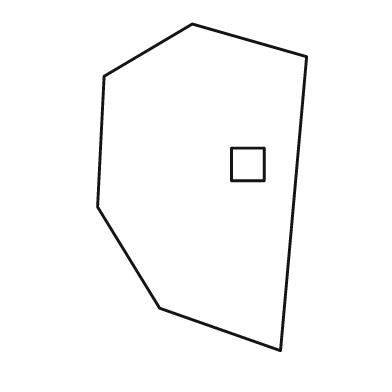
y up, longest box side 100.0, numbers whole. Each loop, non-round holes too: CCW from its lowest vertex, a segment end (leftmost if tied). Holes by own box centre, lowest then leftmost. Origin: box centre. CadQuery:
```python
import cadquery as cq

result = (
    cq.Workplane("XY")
    .moveTo(24.0, -50.0)
    .lineTo(32.0, 40.0)
    .lineTo(-3.0, 50.0)
    .lineTo(-30.0, 34.0)
    .lineTo(-32.0, -6.0)
    .lineTo(-13.0, -37.0)
    .close()
    .moveTo(9.0, 2.0)
    .lineTo(19.0, 2.0)
    .lineTo(19.0, 12.0)
    .lineTo(9.0, 12.0)
    .close()
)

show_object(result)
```